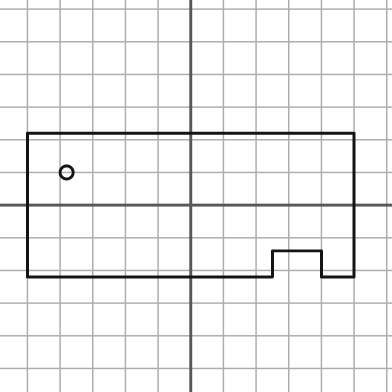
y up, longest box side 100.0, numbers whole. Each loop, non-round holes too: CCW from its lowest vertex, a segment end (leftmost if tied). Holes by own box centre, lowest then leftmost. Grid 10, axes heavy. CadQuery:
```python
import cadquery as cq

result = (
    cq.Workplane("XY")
    .moveTo(-50.0, -22.0)
    .lineTo(25.0, -22.0)
    .lineTo(25.0, -14.0)
    .lineTo(40.0, -14.0)
    .lineTo(40.0, -22.0)
    .lineTo(50.0, -22.0)
    .lineTo(50.0, 22.0)
    .lineTo(-50.0, 22.0)
    .close()
    .moveTo(-38.0, 10.0)
    .circle(2.0)
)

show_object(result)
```